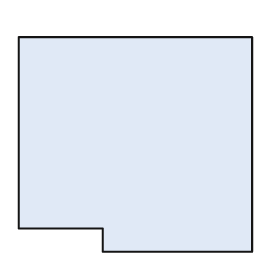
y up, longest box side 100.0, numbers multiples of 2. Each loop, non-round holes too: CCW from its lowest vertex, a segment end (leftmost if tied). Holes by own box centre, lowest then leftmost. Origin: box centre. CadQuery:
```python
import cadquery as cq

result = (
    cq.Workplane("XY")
    .moveTo(-14.0, -46.0)
    .lineTo(50.0, -46.0)
    .lineTo(50.0, 46.0)
    .lineTo(-50.0, 46.0)
    .lineTo(-50.0, -36.0)
    .lineTo(-14.0, -36.0)
    .close()
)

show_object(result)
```